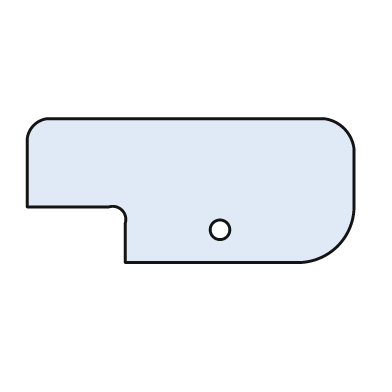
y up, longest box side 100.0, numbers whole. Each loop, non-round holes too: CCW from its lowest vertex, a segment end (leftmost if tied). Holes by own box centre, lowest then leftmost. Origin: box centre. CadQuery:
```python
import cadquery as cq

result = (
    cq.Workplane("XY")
    .moveTo(-20.0, -22.0)
    .lineTo(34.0, -22.0)
    .threePointArc((45.0, -17.0), (50.0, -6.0))
    .lineTo(50.0, 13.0)
    .threePointArc((47.0, 19.0), (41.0, 22.0))
    .lineTo(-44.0, 22.0)
    .threePointArc((-48.0, 20.0), (-50.0, 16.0))
    .lineTo(-50.0, -5.0)
    .lineTo(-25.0, -5.0)
    .threePointArc((-21.0, -6.0), (-20.0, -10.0))
    .close()
    .moveTo(9.0, -12.0)
    .circle(3.0)
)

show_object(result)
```